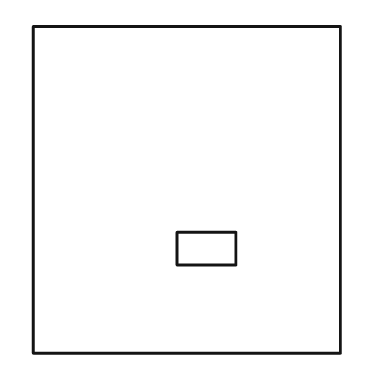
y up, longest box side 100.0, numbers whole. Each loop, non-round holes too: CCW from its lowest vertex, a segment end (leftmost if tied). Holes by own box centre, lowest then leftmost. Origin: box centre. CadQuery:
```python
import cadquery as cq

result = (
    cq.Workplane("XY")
    .moveTo(-47.0, -50.0)
    .lineTo(47.0, -50.0)
    .lineTo(47.0, 50.0)
    .lineTo(-47.0, 50.0)
    .close()
    .moveTo(-3.0, -23.0)
    .lineTo(15.0, -23.0)
    .lineTo(15.0, -13.0)
    .lineTo(-3.0, -13.0)
    .close()
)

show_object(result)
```